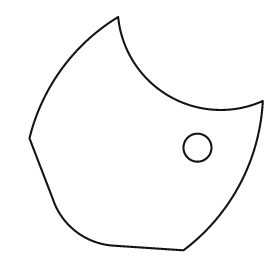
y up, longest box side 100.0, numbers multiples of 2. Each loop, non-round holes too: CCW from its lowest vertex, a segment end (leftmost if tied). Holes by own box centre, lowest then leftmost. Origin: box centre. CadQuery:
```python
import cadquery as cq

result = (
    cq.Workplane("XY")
    .moveTo(16.0, -50.0)
    .threePointArc((40.0, -22.0), (50.0, 14.0))
    .threePointArc((10.0, 16.0), (-12.0, 50.0))
    .threePointArc((-36.0, 28.0), (-50.0, -2.0))
    .lineTo(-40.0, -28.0)
    .threePointArc((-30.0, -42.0), (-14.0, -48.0))
    .close()
    .moveTo(22.0, -6.0)
    .circle(6.0)
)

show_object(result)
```